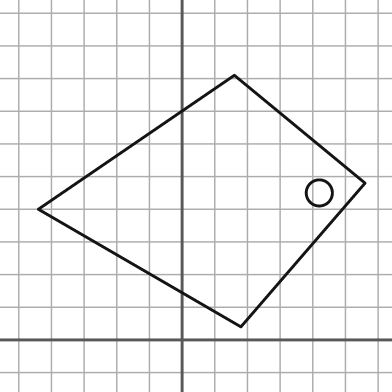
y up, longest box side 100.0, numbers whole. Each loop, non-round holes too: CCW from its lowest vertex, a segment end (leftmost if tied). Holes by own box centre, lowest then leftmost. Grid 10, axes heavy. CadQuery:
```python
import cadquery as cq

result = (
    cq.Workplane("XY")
    .moveTo(18.0, 4.0)
    .lineTo(56.0, 48.0)
    .lineTo(16.0, 81.0)
    .lineTo(-44.0, 40.0)
    .close()
    .moveTo(42.0, 45.0)
    .circle(4.0)
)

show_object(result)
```